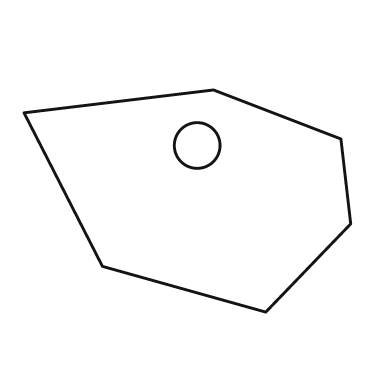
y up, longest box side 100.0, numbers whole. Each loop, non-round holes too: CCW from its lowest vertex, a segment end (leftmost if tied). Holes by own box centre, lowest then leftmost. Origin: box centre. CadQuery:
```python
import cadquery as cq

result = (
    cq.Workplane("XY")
    .moveTo(24.0, -34.0)
    .lineTo(50.0, -7.0)
    .lineTo(47.0, 19.0)
    .lineTo(8.0, 34.0)
    .lineTo(-50.0, 27.0)
    .lineTo(-26.0, -20.0)
    .close()
    .moveTo(3.0, 17.0)
    .circle(7.0)
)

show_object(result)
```